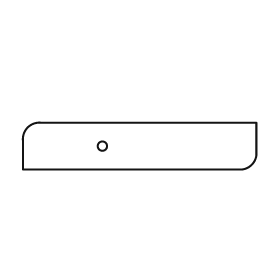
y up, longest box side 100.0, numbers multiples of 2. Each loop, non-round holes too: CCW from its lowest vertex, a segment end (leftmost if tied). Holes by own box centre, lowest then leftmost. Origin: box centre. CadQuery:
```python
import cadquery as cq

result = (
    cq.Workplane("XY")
    .moveTo(-50.0, -10.0)
    .lineTo(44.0, -10.0)
    .threePointArc((48.0, -8.0), (50.0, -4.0))
    .lineTo(50.0, 10.0)
    .lineTo(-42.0, 10.0)
    .threePointArc((-48.0, 8.0), (-50.0, 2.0))
    .close()
    .moveTo(-16.0, 0.0)
    .circle(2.0)
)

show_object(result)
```